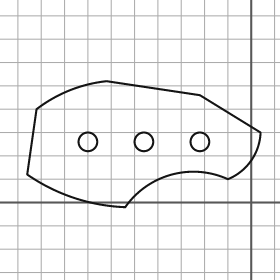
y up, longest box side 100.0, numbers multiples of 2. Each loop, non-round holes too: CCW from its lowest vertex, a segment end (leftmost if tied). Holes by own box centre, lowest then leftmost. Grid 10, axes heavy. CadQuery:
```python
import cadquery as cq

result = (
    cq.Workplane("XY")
    .moveTo(-54.0, -2.0)
    .threePointArc((-34.0, 12.0), (-10.0, 10.0))
    .threePointArc((0.0, 18.0), (4.0, 30.0))
    .lineTo(-22.0, 46.0)
    .lineTo(-62.0, 52.0)
    .threePointArc((-78.0, 48.0), (-92.0, 40.0))
    .lineTo(-96.0, 12.0)
    .threePointArc((-76.0, 2.0), (-54.0, -2.0))
    .close()
    .moveTo(-70.0, 26.0)
    .circle(4.0)
    .moveTo(-46.0, 26.0)
    .circle(4.0)
    .moveTo(-22.0, 26.0)
    .circle(4.0)
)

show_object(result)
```